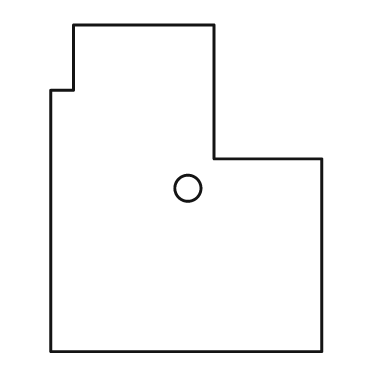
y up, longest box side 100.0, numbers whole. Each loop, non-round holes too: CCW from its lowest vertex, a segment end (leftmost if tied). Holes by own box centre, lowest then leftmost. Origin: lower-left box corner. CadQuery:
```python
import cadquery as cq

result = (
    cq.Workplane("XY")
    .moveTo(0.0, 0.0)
    .lineTo(83.0, 0.0)
    .lineTo(83.0, 59.0)
    .lineTo(50.0, 59.0)
    .lineTo(50.0, 100.0)
    .lineTo(7.0, 100.0)
    .lineTo(7.0, 80.0)
    .lineTo(0.0, 80.0)
    .close()
    .moveTo(42.0, 50.0)
    .circle(4.0)
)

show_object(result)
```